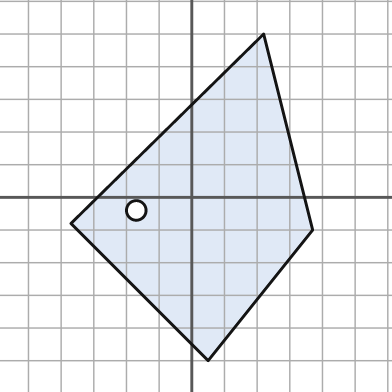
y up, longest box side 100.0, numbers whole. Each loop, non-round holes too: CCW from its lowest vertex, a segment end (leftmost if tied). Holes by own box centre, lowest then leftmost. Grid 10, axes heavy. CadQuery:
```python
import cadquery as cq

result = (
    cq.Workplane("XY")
    .moveTo(5.0, -50.0)
    .lineTo(37.0, -10.0)
    .lineTo(22.0, 50.0)
    .lineTo(-37.0, -8.0)
    .close()
    .moveTo(-17.0, -4.0)
    .circle(3.0)
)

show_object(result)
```